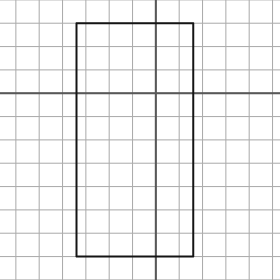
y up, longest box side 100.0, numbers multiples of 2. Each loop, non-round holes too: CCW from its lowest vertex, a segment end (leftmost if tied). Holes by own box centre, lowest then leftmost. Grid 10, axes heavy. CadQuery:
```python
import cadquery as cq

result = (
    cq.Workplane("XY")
    .moveTo(-34.0, -70.0)
    .lineTo(16.0, -70.0)
    .lineTo(16.0, 30.0)
    .lineTo(-34.0, 30.0)
    .close()
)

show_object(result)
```